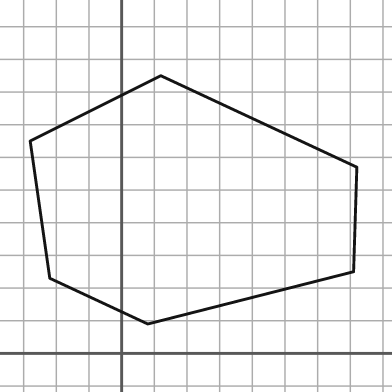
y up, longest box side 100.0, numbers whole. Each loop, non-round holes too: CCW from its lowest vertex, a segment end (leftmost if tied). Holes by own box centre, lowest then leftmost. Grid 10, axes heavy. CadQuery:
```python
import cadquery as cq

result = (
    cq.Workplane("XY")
    .moveTo(8.0, 9.0)
    .lineTo(71.0, 25.0)
    .lineTo(72.0, 57.0)
    .lineTo(12.0, 85.0)
    .lineTo(-28.0, 65.0)
    .lineTo(-22.0, 23.0)
    .close()
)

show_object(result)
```